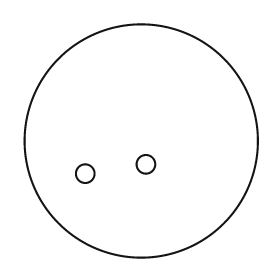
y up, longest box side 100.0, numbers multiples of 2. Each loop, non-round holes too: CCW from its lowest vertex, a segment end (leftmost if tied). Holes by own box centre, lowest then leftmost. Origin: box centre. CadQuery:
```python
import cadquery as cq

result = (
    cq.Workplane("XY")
    .moveTo(0.0, 0.0)
    .circle(50.0)
    .moveTo(-24.0, -14.0)
    .circle(4.0)
    .moveTo(2.0, -10.0)
    .circle(4.0)
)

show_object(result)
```